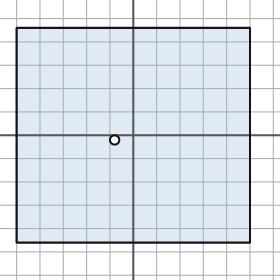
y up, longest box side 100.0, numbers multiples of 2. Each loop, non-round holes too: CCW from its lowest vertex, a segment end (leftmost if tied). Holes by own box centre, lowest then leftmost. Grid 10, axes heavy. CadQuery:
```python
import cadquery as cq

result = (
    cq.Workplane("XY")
    .moveTo(-50.0, -46.0)
    .lineTo(50.0, -46.0)
    .lineTo(50.0, 46.0)
    .lineTo(-50.0, 46.0)
    .close()
    .moveTo(-8.0, -2.0)
    .circle(2.0)
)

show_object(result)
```